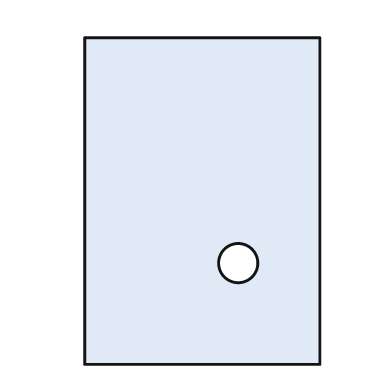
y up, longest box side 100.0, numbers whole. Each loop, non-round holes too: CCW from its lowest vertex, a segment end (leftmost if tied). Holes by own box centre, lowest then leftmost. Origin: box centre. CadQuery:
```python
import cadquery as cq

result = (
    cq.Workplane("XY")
    .moveTo(-36.0, -50.0)
    .lineTo(36.0, -50.0)
    .lineTo(36.0, 50.0)
    .lineTo(-36.0, 50.0)
    .close()
    .moveTo(11.0, -19.0)
    .circle(6.0)
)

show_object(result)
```